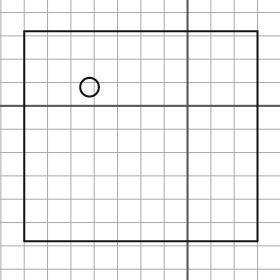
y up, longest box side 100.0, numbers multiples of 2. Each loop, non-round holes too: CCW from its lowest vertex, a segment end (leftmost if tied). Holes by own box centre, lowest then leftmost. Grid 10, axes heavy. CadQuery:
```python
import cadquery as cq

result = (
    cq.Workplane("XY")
    .moveTo(-70.0, -58.0)
    .lineTo(30.0, -58.0)
    .lineTo(30.0, 32.0)
    .lineTo(-70.0, 32.0)
    .close()
    .moveTo(-42.0, 8.0)
    .circle(4.0)
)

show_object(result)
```